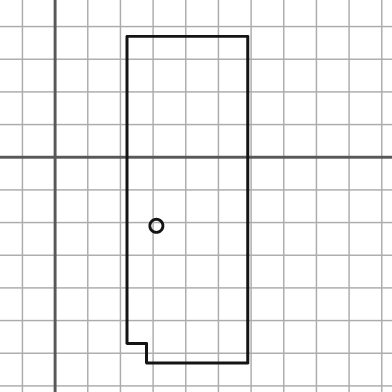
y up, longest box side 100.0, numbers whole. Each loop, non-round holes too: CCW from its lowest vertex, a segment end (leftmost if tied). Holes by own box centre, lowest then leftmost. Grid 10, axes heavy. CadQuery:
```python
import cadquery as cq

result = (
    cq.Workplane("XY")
    .moveTo(28.0, -63.0)
    .lineTo(59.0, -63.0)
    .lineTo(59.0, 37.0)
    .lineTo(22.0, 37.0)
    .lineTo(22.0, -57.0)
    .lineTo(28.0, -57.0)
    .close()
    .moveTo(31.0, -21.0)
    .circle(2.0)
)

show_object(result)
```